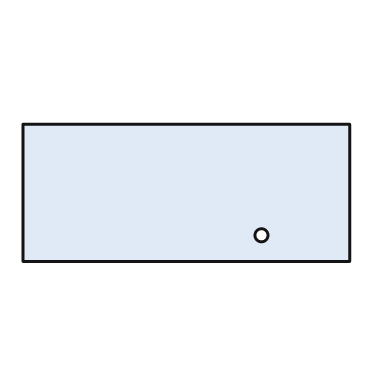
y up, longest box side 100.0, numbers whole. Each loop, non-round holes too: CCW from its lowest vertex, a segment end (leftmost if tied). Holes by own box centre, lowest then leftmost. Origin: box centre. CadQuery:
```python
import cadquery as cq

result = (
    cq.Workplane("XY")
    .moveTo(-50.0, -21.0)
    .lineTo(50.0, -21.0)
    .lineTo(50.0, 21.0)
    .lineTo(-50.0, 21.0)
    .close()
    .moveTo(23.0, -13.0)
    .circle(2.0)
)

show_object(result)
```